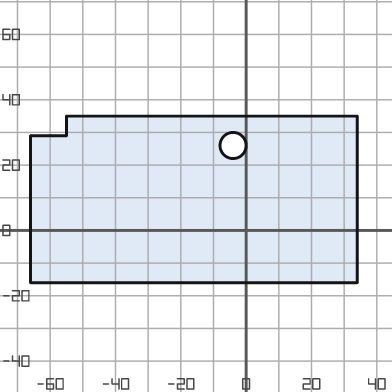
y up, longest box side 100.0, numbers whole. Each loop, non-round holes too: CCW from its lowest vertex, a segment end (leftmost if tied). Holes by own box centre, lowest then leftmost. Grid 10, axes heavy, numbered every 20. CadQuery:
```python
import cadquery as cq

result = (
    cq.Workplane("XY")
    .moveTo(-66.0, -16.0)
    .lineTo(34.0, -16.0)
    .lineTo(34.0, 35.0)
    .lineTo(-55.0, 35.0)
    .lineTo(-55.0, 29.0)
    .lineTo(-66.0, 29.0)
    .close()
    .moveTo(-4.0, 26.0)
    .circle(4.0)
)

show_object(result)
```